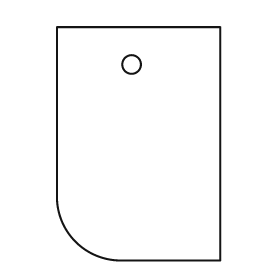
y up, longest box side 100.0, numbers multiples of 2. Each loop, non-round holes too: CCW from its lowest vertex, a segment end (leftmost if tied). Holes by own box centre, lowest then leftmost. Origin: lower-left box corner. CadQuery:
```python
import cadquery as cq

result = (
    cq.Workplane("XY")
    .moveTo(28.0, 0.0)
    .lineTo(70.0, 0.0)
    .lineTo(70.0, 100.0)
    .lineTo(0.0, 100.0)
    .lineTo(0.0, 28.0)
    .threePointArc((8.0, 8.0), (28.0, 0.0))
    .close()
    .moveTo(32.0, 84.0)
    .circle(4.0)
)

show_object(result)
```